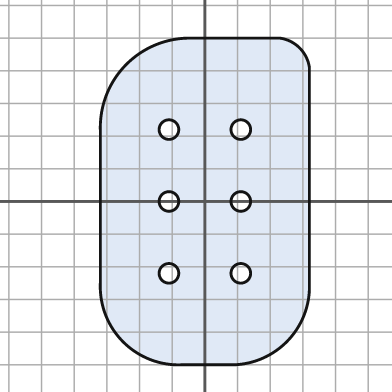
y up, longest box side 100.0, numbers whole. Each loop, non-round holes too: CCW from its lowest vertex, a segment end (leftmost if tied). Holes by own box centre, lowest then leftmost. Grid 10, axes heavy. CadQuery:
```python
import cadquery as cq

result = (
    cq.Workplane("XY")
    .moveTo(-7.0, -50.0)
    .lineTo(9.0, -50.0)
    .threePointArc((25.0, -43.0), (32.0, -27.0))
    .lineTo(32.0, 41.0)
    .threePointArc((29.0, 47.0), (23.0, 50.0))
    .lineTo(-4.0, 50.0)
    .threePointArc((-24.0, 42.0), (-32.0, 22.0))
    .lineTo(-32.0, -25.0)
    .threePointArc((-25.0, -43.0), (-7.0, -50.0))
    .close()
    .moveTo(-11.0, -22.0)
    .circle(3.0)
    .moveTo(11.0, -22.0)
    .circle(3.0)
    .moveTo(-11.0, 0.0)
    .circle(3.0)
    .moveTo(11.0, 0.0)
    .circle(3.0)
    .moveTo(-11.0, 22.0)
    .circle(3.0)
    .moveTo(11.0, 22.0)
    .circle(3.0)
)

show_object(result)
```